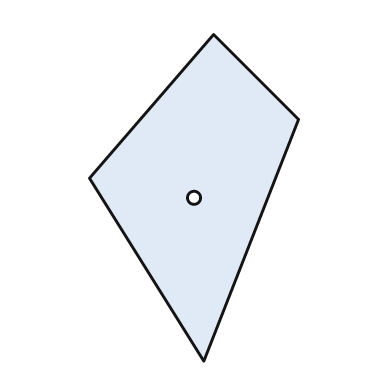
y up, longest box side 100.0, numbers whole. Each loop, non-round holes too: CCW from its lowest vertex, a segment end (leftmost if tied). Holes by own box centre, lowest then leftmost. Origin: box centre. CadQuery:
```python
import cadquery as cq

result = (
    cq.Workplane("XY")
    .moveTo(3.0, -50.0)
    .lineTo(32.0, 24.0)
    .lineTo(6.0, 50.0)
    .lineTo(-32.0, 6.0)
    .close()
    .moveTo(0.0, 0.0)
    .circle(2.0)
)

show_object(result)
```